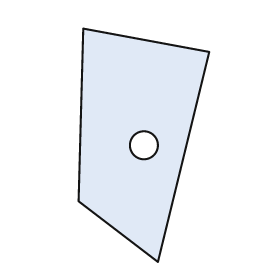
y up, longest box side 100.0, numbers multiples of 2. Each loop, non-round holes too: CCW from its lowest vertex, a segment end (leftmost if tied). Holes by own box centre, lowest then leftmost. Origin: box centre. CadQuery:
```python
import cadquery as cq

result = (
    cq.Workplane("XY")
    .moveTo(6.0, -50.0)
    .lineTo(28.0, 40.0)
    .lineTo(-26.0, 50.0)
    .lineTo(-28.0, -24.0)
    .close()
    .moveTo(0.0, 0.0)
    .circle(6.0)
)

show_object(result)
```